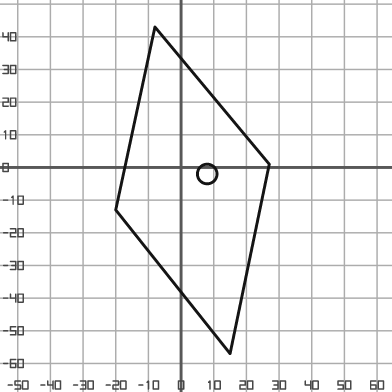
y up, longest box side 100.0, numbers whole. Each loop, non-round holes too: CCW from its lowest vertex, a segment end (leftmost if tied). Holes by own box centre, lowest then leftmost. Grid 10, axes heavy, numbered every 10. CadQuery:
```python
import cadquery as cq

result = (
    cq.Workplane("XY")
    .moveTo(15.0, -57.0)
    .lineTo(27.0, 1.0)
    .lineTo(-8.0, 43.0)
    .lineTo(-20.0, -13.0)
    .close()
    .moveTo(8.0, -2.0)
    .circle(3.0)
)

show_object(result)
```